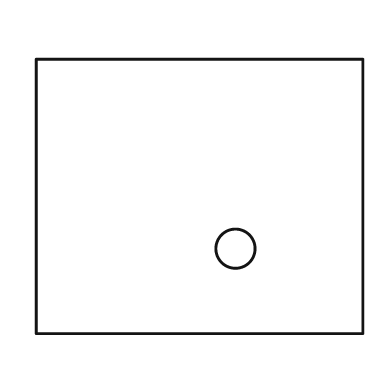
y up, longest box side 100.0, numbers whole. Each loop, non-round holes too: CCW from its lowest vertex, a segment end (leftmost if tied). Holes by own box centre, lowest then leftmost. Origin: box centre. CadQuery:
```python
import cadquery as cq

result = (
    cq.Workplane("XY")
    .moveTo(-50.0, -42.0)
    .lineTo(50.0, -42.0)
    .lineTo(50.0, 42.0)
    .lineTo(-50.0, 42.0)
    .close()
    .moveTo(11.0, -16.0)
    .circle(6.0)
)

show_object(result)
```